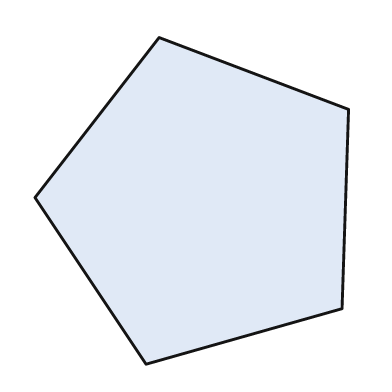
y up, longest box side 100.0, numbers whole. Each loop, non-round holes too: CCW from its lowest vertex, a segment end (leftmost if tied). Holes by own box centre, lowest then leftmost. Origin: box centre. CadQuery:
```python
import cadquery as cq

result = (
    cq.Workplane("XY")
    .moveTo(-14.0, -50.0)
    .lineTo(46.0, -33.0)
    .lineTo(48.0, 28.0)
    .lineTo(-10.0, 50.0)
    .lineTo(-48.0, 1.0)
    .close()
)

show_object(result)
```